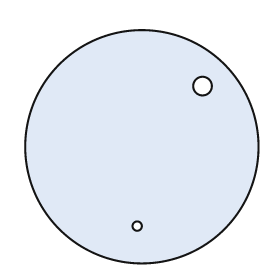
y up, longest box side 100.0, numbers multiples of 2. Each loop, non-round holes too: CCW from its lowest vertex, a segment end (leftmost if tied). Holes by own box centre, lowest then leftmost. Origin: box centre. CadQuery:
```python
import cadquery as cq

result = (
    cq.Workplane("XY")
    .moveTo(0.0, 0.0)
    .circle(50.0)
    .moveTo(-2.0, -34.0)
    .circle(2.0)
    .moveTo(26.0, 26.0)
    .circle(4.0)
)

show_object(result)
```